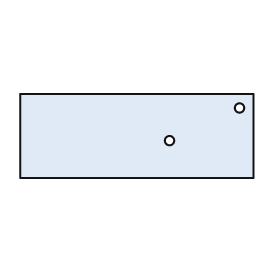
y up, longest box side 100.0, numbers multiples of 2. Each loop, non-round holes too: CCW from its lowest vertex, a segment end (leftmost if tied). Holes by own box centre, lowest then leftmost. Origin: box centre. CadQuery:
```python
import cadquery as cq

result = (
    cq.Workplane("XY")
    .moveTo(-50.0, -18.0)
    .lineTo(50.0, -18.0)
    .lineTo(50.0, 18.0)
    .lineTo(-50.0, 18.0)
    .close()
    .moveTo(14.0, -2.0)
    .circle(2.0)
    .moveTo(44.0, 12.0)
    .circle(2.0)
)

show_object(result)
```